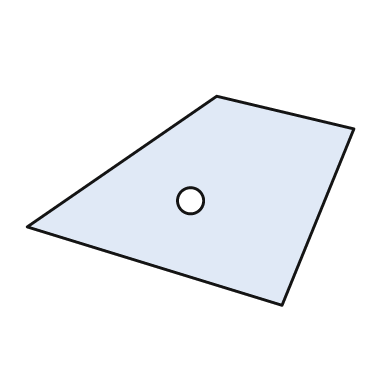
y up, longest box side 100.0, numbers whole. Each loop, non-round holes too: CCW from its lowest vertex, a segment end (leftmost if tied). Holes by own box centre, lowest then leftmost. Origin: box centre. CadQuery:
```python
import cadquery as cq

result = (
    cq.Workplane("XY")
    .moveTo(28.0, -32.0)
    .lineTo(50.0, 22.0)
    .lineTo(8.0, 32.0)
    .lineTo(-50.0, -8.0)
    .close()
    .moveTo(0.0, 0.0)
    .circle(4.0)
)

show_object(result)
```